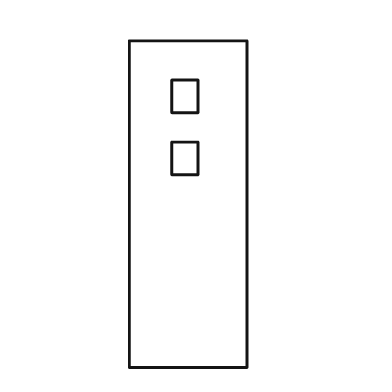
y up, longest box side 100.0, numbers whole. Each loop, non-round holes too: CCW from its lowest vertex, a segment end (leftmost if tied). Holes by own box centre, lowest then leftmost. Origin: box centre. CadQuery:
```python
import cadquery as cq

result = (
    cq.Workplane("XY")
    .moveTo(-18.0, -50.0)
    .lineTo(18.0, -50.0)
    .lineTo(18.0, 50.0)
    .lineTo(-18.0, 50.0)
    .close()
    .moveTo(-5.0, 9.0)
    .lineTo(3.0, 9.0)
    .lineTo(3.0, 19.0)
    .lineTo(-5.0, 19.0)
    .close()
    .moveTo(-5.0, 28.0)
    .lineTo(3.0, 28.0)
    .lineTo(3.0, 38.0)
    .lineTo(-5.0, 38.0)
    .close()
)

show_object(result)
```